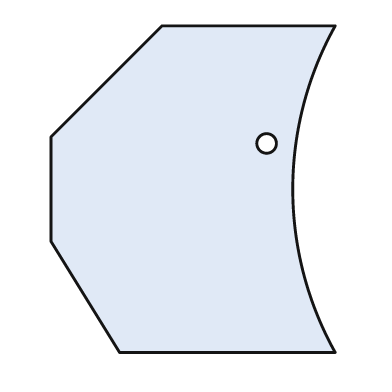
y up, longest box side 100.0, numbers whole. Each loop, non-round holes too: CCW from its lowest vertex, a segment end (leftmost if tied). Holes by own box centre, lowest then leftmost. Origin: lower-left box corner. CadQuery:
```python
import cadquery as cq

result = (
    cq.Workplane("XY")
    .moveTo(21.0, 0.0)
    .lineTo(87.0, 0.0)
    .threePointArc((74.0, 50.0), (87.0, 100.0))
    .lineTo(34.0, 100.0)
    .lineTo(0.0, 66.0)
    .lineTo(0.0, 34.0)
    .close()
    .moveTo(66.0, 64.0)
    .circle(3.0)
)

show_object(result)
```